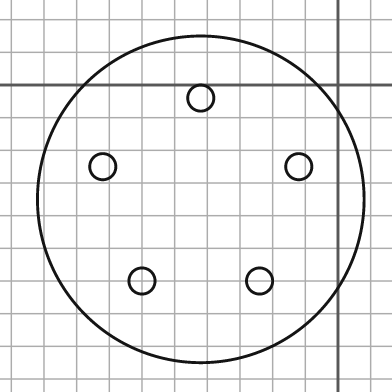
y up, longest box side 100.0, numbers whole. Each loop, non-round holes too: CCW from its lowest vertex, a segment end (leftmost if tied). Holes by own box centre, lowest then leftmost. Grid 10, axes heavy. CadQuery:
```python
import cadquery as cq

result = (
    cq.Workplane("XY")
    .moveTo(-42.0, -35.0)
    .circle(50.0)
    .moveTo(-60.0, -60.0)
    .circle(4.0)
    .moveTo(-24.0, -60.0)
    .circle(4.0)
    .moveTo(-72.0, -25.0)
    .circle(4.0)
    .moveTo(-12.0, -25.0)
    .circle(4.0)
    .moveTo(-42.0, -4.0)
    .circle(4.0)
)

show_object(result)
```